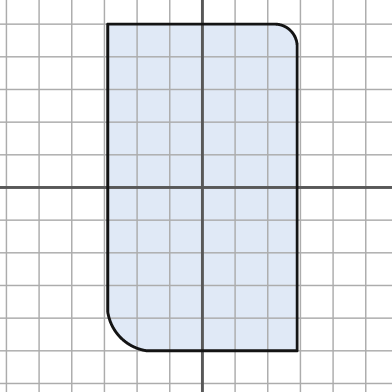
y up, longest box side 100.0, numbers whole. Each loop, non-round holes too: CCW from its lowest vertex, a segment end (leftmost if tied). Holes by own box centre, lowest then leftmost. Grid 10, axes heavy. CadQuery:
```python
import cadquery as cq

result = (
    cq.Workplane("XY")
    .moveTo(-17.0, -50.0)
    .lineTo(29.0, -50.0)
    .lineTo(29.0, 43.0)
    .threePointArc((27.0, 48.0), (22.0, 50.0))
    .lineTo(-29.0, 50.0)
    .lineTo(-29.0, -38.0)
    .threePointArc((-25.0, -46.0), (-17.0, -50.0))
    .close()
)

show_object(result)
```